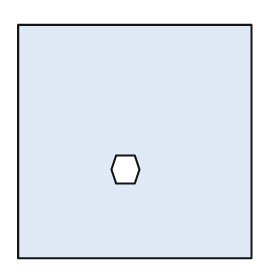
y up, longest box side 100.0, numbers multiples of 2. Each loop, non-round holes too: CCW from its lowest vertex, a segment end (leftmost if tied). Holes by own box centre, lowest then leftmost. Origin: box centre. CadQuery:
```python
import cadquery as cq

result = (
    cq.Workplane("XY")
    .moveTo(-50.0, -50.0)
    .lineTo(50.0, -50.0)
    .lineTo(50.0, 50.0)
    .lineTo(-50.0, 50.0)
    .close()
    .moveTo(-8.0, -18.0)
    .lineTo(0.0, -18.0)
    .lineTo(2.0, -12.0)
    .lineTo(0.0, -6.0)
    .lineTo(-8.0, -6.0)
    .lineTo(-10.0, -12.0)
    .close()
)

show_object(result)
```